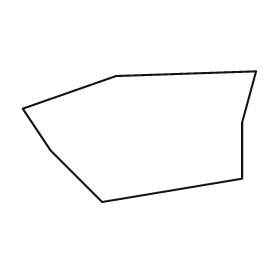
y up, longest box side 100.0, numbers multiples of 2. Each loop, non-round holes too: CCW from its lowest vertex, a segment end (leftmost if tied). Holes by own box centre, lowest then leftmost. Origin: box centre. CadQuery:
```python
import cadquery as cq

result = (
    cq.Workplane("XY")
    .moveTo(-16.0, -28.0)
    .lineTo(44.0, -18.0)
    .lineTo(44.0, 6.0)
    .lineTo(50.0, 28.0)
    .lineTo(-10.0, 26.0)
    .lineTo(-50.0, 12.0)
    .lineTo(-38.0, -6.0)
    .close()
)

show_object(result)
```